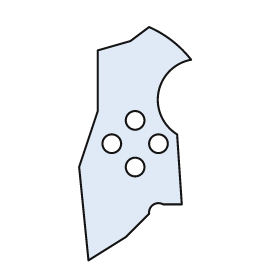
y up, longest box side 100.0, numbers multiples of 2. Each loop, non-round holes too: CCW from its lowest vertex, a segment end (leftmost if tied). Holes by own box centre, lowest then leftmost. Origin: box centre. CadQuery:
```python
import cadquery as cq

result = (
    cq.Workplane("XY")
    .moveTo(-20.0, -50.0)
    .lineTo(-4.0, -40.0)
    .lineTo(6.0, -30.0)
    .threePointArc((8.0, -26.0), (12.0, -26.0))
    .lineTo(20.0, -26.0)
    .lineTo(18.0, 4.0)
    .threePointArc((10.0, 22.0), (24.0, 36.0))
    .threePointArc((16.0, 44.0), (6.0, 50.0))
    .lineTo(-2.0, 44.0)
    .lineTo(-16.0, 40.0)
    .lineTo(-16.0, 14.0)
    .lineTo(-24.0, -10.0)
    .close()
    .moveTo(0.0, -10.0)
    .circle(4.0)
    .moveTo(-10.0, 0.0)
    .circle(4.0)
    .moveTo(10.0, 0.0)
    .circle(4.0)
    .moveTo(0.0, 10.0)
    .circle(4.0)
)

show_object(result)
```